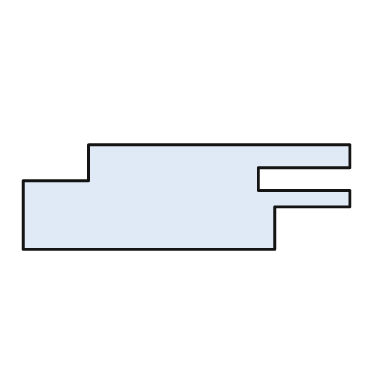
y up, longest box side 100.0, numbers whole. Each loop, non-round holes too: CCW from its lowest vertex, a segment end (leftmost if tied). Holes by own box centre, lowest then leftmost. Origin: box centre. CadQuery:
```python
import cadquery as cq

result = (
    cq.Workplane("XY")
    .moveTo(-50.0, -16.0)
    .lineTo(27.0, -16.0)
    .lineTo(27.0, -3.0)
    .lineTo(50.0, -3.0)
    .lineTo(50.0, 2.0)
    .lineTo(22.0, 2.0)
    .lineTo(22.0, 9.0)
    .lineTo(50.0, 9.0)
    .lineTo(50.0, 16.0)
    .lineTo(-30.0, 16.0)
    .lineTo(-30.0, 5.0)
    .lineTo(-50.0, 5.0)
    .close()
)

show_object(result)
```